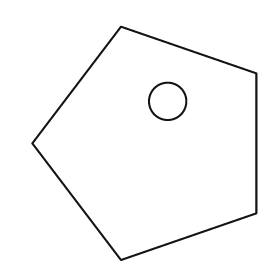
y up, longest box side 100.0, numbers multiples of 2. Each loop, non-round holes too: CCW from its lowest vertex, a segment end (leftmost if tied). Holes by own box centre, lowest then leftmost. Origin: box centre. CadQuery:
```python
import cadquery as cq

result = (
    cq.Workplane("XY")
    .moveTo(-10.0, -50.0)
    .lineTo(48.0, -30.0)
    .lineTo(48.0, 30.0)
    .lineTo(-10.0, 50.0)
    .lineTo(-48.0, 0.0)
    .close()
    .moveTo(10.0, 18.0)
    .circle(8.0)
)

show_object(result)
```